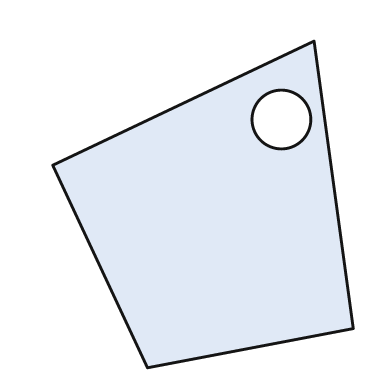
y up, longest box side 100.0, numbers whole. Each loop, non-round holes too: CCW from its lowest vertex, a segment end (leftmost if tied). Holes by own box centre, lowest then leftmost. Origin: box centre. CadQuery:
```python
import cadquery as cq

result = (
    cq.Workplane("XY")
    .moveTo(-17.0, -50.0)
    .lineTo(46.0, -38.0)
    .lineTo(34.0, 50.0)
    .lineTo(-46.0, 12.0)
    .close()
    .moveTo(24.0, 26.0)
    .circle(9.0)
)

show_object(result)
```